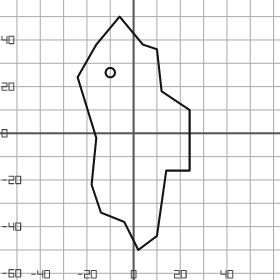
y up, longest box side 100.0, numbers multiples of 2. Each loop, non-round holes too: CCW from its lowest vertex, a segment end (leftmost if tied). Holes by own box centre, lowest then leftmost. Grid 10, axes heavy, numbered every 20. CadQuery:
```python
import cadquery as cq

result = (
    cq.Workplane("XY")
    .moveTo(2.0, -50.0)
    .lineTo(10.0, -44.0)
    .lineTo(14.0, -16.0)
    .lineTo(24.0, -16.0)
    .lineTo(24.0, 10.0)
    .lineTo(12.0, 18.0)
    .lineTo(10.0, 36.0)
    .lineTo(4.0, 38.0)
    .lineTo(-6.0, 50.0)
    .lineTo(-16.0, 38.0)
    .lineTo(-24.0, 24.0)
    .lineTo(-16.0, -2.0)
    .lineTo(-18.0, -22.0)
    .lineTo(-14.0, -34.0)
    .lineTo(-4.0, -38.0)
    .close()
    .moveTo(-10.0, 26.0)
    .circle(2.0)
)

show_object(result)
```